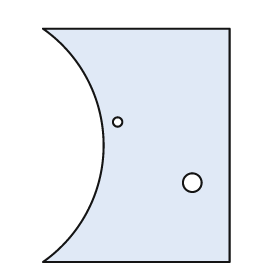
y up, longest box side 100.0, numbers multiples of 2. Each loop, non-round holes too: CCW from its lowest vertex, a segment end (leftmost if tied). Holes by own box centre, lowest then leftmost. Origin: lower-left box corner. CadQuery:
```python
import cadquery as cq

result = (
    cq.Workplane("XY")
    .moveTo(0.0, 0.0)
    .lineTo(80.0, 0.0)
    .lineTo(80.0, 100.0)
    .lineTo(0.0, 100.0)
    .threePointArc((26.0, 50.0), (0.0, 0.0))
    .close()
    .moveTo(64.0, 34.0)
    .circle(4.0)
    .moveTo(32.0, 60.0)
    .circle(2.0)
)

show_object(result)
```